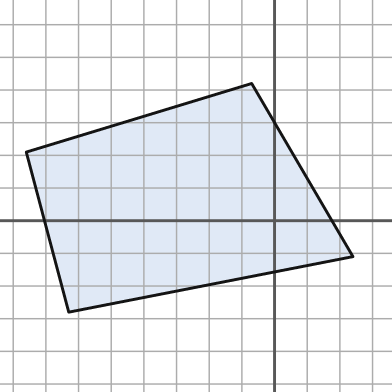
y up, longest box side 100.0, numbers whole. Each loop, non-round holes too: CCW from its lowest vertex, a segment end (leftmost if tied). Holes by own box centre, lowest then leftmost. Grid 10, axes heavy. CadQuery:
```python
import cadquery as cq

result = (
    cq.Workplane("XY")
    .moveTo(-63.0, -28.0)
    .lineTo(24.0, -11.0)
    .lineTo(-7.0, 42.0)
    .lineTo(-76.0, 21.0)
    .close()
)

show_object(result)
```